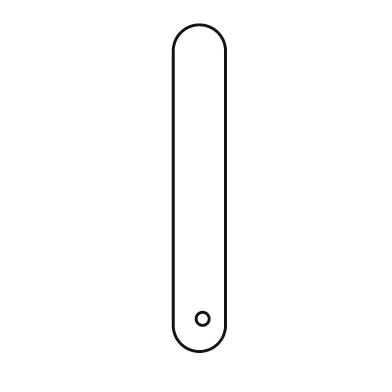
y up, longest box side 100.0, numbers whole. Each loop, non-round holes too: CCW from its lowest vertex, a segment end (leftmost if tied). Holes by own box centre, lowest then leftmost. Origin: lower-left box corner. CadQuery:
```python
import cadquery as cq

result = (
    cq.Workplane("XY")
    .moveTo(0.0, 8.0)
    .threePointArc((8.0, 0.0), (16.0, 8.0))
    .lineTo(16.0, 92.0)
    .threePointArc((8.0, 100.0), (0.0, 92.0))
    .close()
    .moveTo(9.0, 10.0)
    .circle(2.0)
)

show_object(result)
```